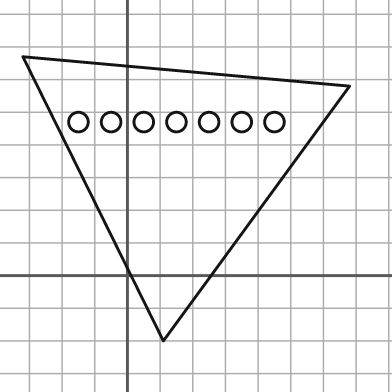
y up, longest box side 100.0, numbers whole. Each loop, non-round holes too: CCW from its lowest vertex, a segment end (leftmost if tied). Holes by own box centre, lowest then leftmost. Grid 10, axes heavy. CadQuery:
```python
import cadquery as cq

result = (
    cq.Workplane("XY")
    .moveTo(11.0, -20.0)
    .lineTo(68.0, 58.0)
    .lineTo(-32.0, 67.0)
    .close()
    .moveTo(-15.0, 47.0)
    .circle(3.0)
    .moveTo(-5.0, 47.0)
    .circle(3.0)
    .moveTo(5.0, 47.0)
    .circle(3.0)
    .moveTo(15.0, 47.0)
    .circle(3.0)
    .moveTo(25.0, 47.0)
    .circle(3.0)
    .moveTo(35.0, 47.0)
    .circle(3.0)
    .moveTo(45.0, 47.0)
    .circle(3.0)
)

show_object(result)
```